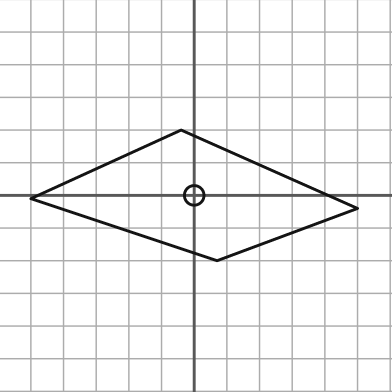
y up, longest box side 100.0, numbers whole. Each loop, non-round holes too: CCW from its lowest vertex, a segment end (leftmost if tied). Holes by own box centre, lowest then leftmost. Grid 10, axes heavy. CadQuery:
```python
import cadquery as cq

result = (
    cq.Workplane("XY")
    .moveTo(7.0, -20.0)
    .lineTo(50.0, -4.0)
    .lineTo(-4.0, 20.0)
    .lineTo(-50.0, -1.0)
    .close()
    .moveTo(0.0, 0.0)
    .circle(3.0)
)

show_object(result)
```